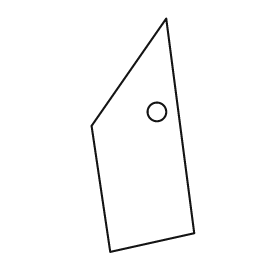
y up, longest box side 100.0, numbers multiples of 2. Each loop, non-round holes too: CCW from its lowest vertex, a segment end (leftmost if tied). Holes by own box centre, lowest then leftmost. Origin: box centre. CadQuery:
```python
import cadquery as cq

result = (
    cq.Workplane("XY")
    .moveTo(-14.0, -50.0)
    .lineTo(22.0, -42.0)
    .lineTo(10.0, 50.0)
    .lineTo(-22.0, 4.0)
    .close()
    .moveTo(6.0, 10.0)
    .circle(4.0)
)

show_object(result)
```